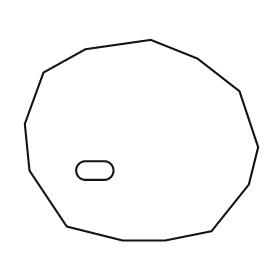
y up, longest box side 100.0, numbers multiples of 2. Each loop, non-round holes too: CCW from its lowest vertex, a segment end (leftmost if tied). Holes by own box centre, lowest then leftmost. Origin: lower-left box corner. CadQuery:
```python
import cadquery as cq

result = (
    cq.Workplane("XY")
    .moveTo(42.0, 0.0)
    .lineTo(60.0, 0.0)
    .lineTo(80.0, 4.0)
    .lineTo(96.0, 24.0)
    .lineTo(100.0, 40.0)
    .lineTo(92.0, 64.0)
    .lineTo(74.0, 78.0)
    .lineTo(54.0, 86.0)
    .lineTo(26.0, 82.0)
    .lineTo(8.0, 72.0)
    .lineTo(0.0, 50.0)
    .lineTo(2.0, 30.0)
    .lineTo(18.0, 6.0)
    .close()
    .moveTo(26.0, 26.0)
    .lineTo(34.0, 26.0)
    .threePointArc((38.0, 30.0), (34.0, 34.0))
    .lineTo(26.0, 34.0)
    .threePointArc((22.0, 30.0), (26.0, 26.0))
    .close()
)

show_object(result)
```